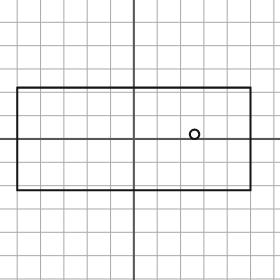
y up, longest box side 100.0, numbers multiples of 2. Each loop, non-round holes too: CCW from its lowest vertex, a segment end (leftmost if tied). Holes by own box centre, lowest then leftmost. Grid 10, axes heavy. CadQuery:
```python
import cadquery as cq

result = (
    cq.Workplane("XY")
    .moveTo(-50.0, -22.0)
    .lineTo(50.0, -22.0)
    .lineTo(50.0, 22.0)
    .lineTo(-50.0, 22.0)
    .close()
    .moveTo(26.0, 2.0)
    .circle(2.0)
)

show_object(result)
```